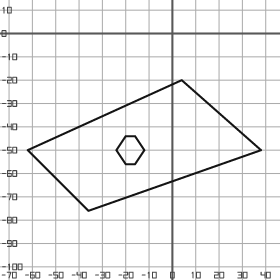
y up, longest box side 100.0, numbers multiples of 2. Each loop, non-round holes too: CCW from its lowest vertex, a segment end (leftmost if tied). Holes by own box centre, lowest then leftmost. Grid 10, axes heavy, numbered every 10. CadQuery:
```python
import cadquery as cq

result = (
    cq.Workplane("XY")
    .moveTo(-36.0, -76.0)
    .lineTo(38.0, -50.0)
    .lineTo(4.0, -20.0)
    .lineTo(-62.0, -50.0)
    .close()
    .moveTo(-20.0, -56.0)
    .lineTo(-16.0, -56.0)
    .lineTo(-12.0, -50.0)
    .lineTo(-16.0, -44.0)
    .lineTo(-20.0, -44.0)
    .lineTo(-24.0, -50.0)
    .close()
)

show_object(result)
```